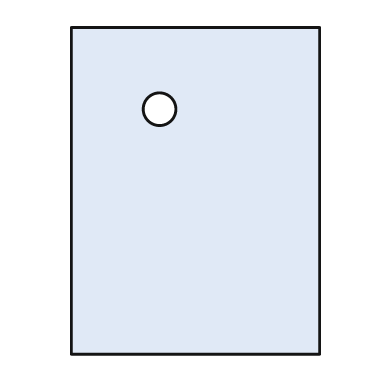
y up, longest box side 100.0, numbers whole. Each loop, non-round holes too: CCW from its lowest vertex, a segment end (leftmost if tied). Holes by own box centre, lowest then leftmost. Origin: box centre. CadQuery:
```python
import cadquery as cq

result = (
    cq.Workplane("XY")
    .moveTo(-38.0, -50.0)
    .lineTo(38.0, -50.0)
    .lineTo(38.0, 50.0)
    .lineTo(-38.0, 50.0)
    .close()
    .moveTo(-11.0, 25.0)
    .circle(5.0)
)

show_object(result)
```